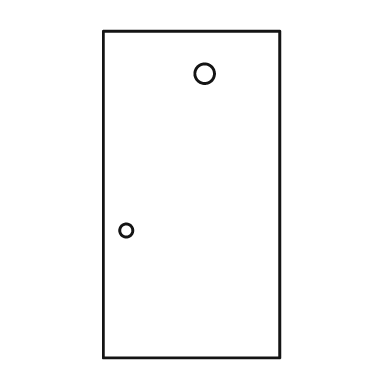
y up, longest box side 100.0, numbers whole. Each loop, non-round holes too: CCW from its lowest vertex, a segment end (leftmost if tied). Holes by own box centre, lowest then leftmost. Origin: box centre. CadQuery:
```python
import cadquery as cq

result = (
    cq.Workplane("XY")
    .moveTo(-27.0, -50.0)
    .lineTo(27.0, -50.0)
    .lineTo(27.0, 50.0)
    .lineTo(-27.0, 50.0)
    .close()
    .moveTo(-20.0, -11.0)
    .circle(2.0)
    .moveTo(4.0, 37.0)
    .circle(3.0)
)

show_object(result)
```